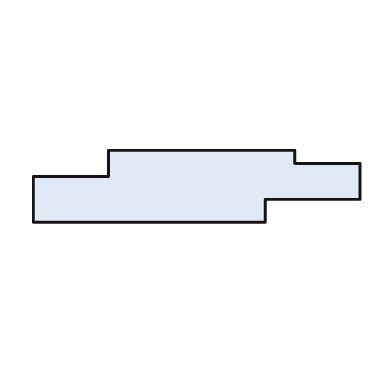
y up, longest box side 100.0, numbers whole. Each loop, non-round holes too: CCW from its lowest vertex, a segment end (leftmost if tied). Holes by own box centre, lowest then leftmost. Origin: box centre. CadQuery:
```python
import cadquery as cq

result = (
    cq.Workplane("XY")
    .moveTo(-50.0, -11.0)
    .lineTo(21.0, -11.0)
    .lineTo(21.0, -4.0)
    .lineTo(50.0, -4.0)
    .lineTo(50.0, 7.0)
    .lineTo(30.0, 7.0)
    .lineTo(30.0, 11.0)
    .lineTo(-27.0, 11.0)
    .lineTo(-27.0, 3.0)
    .lineTo(-50.0, 3.0)
    .close()
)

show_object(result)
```